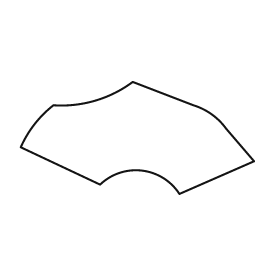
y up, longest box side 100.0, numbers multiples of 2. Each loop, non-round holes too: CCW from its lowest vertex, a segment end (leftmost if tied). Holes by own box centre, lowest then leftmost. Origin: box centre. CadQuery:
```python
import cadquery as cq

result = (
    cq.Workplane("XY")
    .moveTo(18.0, -24.0)
    .lineTo(50.0, -10.0)
    .lineTo(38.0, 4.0)
    .threePointArc((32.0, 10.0), (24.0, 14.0))
    .lineTo(-2.0, 24.0)
    .threePointArc((-18.0, 16.0), (-36.0, 14.0))
    .threePointArc((-44.0, 6.0), (-50.0, -4.0))
    .lineTo(-16.0, -20.0)
    .threePointArc((2.0, -14.0), (18.0, -24.0))
    .close()
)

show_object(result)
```